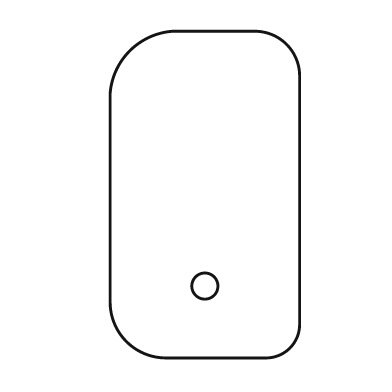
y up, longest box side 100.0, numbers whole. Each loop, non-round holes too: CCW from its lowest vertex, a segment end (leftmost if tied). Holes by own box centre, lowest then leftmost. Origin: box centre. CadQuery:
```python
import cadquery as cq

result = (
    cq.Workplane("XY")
    .moveTo(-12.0, -50.0)
    .lineTo(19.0, -50.0)
    .threePointArc((26.0, -47.0), (29.0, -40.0))
    .lineTo(29.0, 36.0)
    .threePointArc((25.0, 46.0), (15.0, 50.0))
    .lineTo(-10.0, 50.0)
    .threePointArc((-23.0, 44.0), (-29.0, 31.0))
    .lineTo(-29.0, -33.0)
    .threePointArc((-24.0, -45.0), (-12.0, -50.0))
    .close()
    .moveTo(0.0, -28.0)
    .circle(4.0)
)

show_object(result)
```